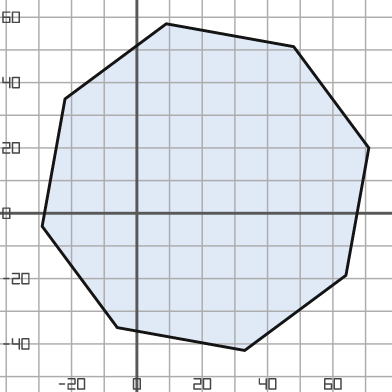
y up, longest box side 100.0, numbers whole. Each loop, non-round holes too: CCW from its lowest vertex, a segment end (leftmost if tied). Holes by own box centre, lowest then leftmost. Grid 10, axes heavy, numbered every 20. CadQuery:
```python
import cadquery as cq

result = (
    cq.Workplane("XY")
    .moveTo(33.0, -42.0)
    .lineTo(64.0, -19.0)
    .lineTo(71.0, 20.0)
    .lineTo(48.0, 51.0)
    .lineTo(9.0, 58.0)
    .lineTo(-22.0, 35.0)
    .lineTo(-29.0, -4.0)
    .lineTo(-6.0, -35.0)
    .close()
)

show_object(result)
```